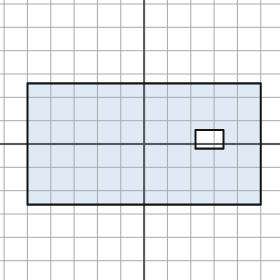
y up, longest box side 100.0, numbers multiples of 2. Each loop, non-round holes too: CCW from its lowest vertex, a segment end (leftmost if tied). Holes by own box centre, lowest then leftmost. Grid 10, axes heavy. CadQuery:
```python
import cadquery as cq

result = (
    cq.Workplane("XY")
    .moveTo(-50.0, -26.0)
    .lineTo(50.0, -26.0)
    .lineTo(50.0, 26.0)
    .lineTo(-50.0, 26.0)
    .close()
    .moveTo(22.0, -2.0)
    .lineTo(34.0, -2.0)
    .lineTo(34.0, 6.0)
    .lineTo(22.0, 6.0)
    .close()
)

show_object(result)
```